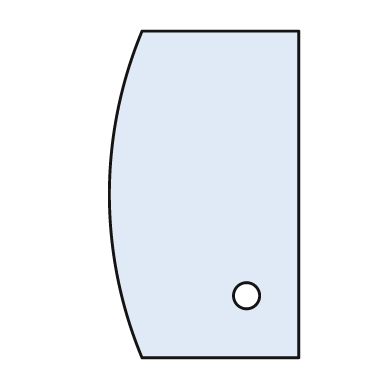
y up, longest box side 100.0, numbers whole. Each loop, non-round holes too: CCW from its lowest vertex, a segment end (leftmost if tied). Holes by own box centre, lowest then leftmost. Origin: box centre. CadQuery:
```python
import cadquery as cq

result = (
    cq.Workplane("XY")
    .moveTo(-19.0, -50.0)
    .lineTo(29.0, -50.0)
    .lineTo(29.0, 50.0)
    .lineTo(-19.0, 50.0)
    .threePointArc((-29.0, 0.0), (-19.0, -50.0))
    .close()
    .moveTo(13.0, -31.0)
    .circle(4.0)
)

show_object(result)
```